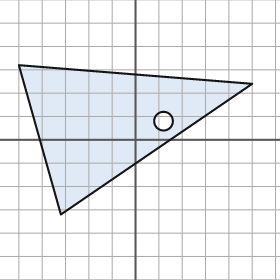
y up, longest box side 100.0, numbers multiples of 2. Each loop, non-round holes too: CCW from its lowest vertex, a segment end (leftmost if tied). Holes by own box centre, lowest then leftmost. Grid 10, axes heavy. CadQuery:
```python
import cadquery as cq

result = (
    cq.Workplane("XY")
    .moveTo(-32.0, -32.0)
    .lineTo(50.0, 24.0)
    .lineTo(-50.0, 32.0)
    .close()
    .moveTo(12.0, 8.0)
    .circle(4.0)
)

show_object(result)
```